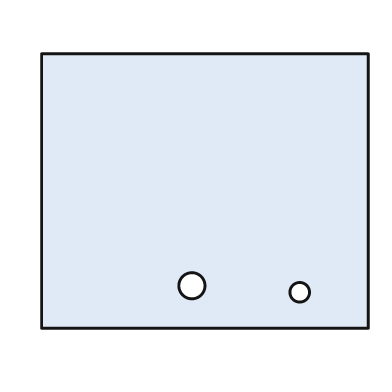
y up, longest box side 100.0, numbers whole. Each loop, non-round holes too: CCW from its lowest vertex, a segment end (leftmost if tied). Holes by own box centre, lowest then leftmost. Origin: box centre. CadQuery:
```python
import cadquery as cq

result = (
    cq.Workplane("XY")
    .moveTo(-50.0, -42.0)
    .lineTo(50.0, -42.0)
    .lineTo(50.0, 42.0)
    .lineTo(-50.0, 42.0)
    .close()
    .moveTo(29.0, -31.0)
    .circle(3.0)
    .moveTo(-4.0, -29.0)
    .circle(4.0)
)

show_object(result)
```